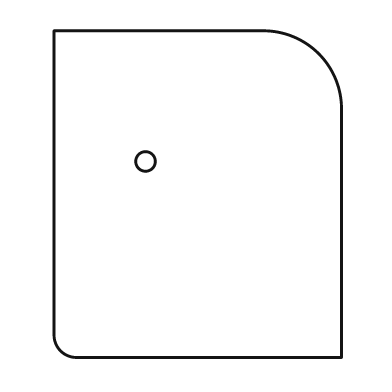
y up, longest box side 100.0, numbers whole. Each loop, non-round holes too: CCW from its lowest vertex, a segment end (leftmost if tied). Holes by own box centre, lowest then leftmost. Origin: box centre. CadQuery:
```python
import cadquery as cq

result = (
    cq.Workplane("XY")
    .moveTo(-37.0, -50.0)
    .lineTo(44.0, -50.0)
    .lineTo(44.0, 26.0)
    .threePointArc((37.0, 43.0), (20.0, 50.0))
    .lineTo(-44.0, 50.0)
    .lineTo(-44.0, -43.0)
    .threePointArc((-42.0, -48.0), (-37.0, -50.0))
    .close()
    .moveTo(-16.0, 10.0)
    .circle(3.0)
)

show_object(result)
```